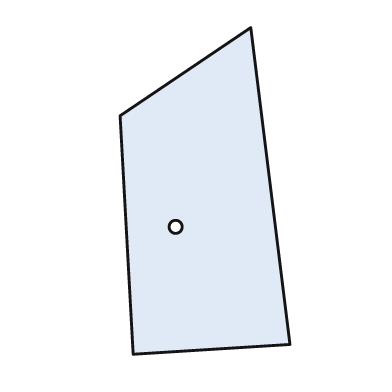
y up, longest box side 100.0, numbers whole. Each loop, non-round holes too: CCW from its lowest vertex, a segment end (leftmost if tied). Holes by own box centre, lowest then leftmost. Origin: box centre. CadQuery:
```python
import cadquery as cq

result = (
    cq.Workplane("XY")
    .moveTo(-22.0, -50.0)
    .lineTo(26.0, -47.0)
    .lineTo(14.0, 50.0)
    .lineTo(-26.0, 23.0)
    .close()
    .moveTo(-9.0, -11.0)
    .circle(2.0)
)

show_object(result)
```